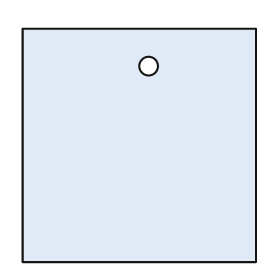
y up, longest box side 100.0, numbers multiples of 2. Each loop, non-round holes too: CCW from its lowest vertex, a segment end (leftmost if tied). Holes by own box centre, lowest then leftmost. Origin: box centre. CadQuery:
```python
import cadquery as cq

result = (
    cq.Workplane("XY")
    .moveTo(-50.0, -50.0)
    .lineTo(50.0, -50.0)
    .lineTo(50.0, 50.0)
    .lineTo(-50.0, 50.0)
    .close()
    .moveTo(4.0, 34.0)
    .circle(4.0)
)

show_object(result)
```